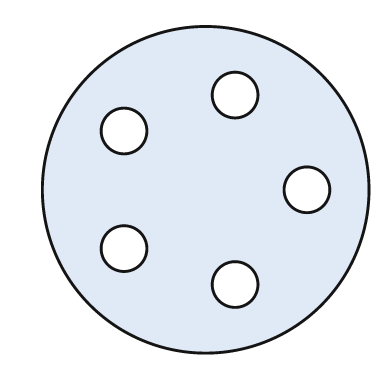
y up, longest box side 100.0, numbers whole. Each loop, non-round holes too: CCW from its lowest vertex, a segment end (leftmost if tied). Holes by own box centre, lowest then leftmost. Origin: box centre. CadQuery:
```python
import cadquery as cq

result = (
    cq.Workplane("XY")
    .moveTo(0.0, 0.0)
    .circle(50.0)
    .moveTo(9.0, -29.0)
    .circle(7.0)
    .moveTo(-25.0, -18.0)
    .circle(7.0)
    .moveTo(31.0, 0.0)
    .circle(7.0)
    .moveTo(-25.0, 18.0)
    .circle(7.0)
    .moveTo(9.0, 29.0)
    .circle(7.0)
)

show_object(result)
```